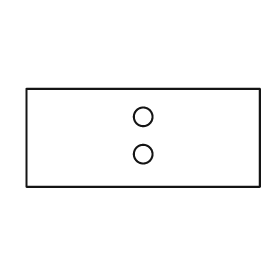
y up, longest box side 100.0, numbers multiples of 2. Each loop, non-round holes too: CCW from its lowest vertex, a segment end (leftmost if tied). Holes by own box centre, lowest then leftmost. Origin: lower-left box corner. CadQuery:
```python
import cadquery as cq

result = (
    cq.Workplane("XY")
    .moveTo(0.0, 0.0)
    .lineTo(100.0, 0.0)
    .lineTo(100.0, 42.0)
    .lineTo(0.0, 42.0)
    .close()
    .moveTo(50.0, 14.0)
    .circle(4.0)
    .moveTo(50.0, 30.0)
    .circle(4.0)
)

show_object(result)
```